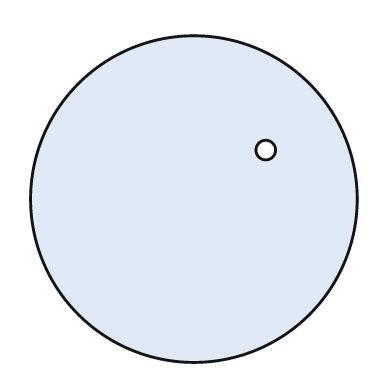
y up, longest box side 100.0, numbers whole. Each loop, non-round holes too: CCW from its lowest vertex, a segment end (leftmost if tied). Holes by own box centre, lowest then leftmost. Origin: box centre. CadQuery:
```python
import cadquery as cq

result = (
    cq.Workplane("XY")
    .moveTo(0.0, 0.0)
    .circle(50.0)
    .moveTo(22.0, 15.0)
    .circle(3.0)
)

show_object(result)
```